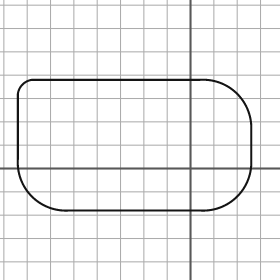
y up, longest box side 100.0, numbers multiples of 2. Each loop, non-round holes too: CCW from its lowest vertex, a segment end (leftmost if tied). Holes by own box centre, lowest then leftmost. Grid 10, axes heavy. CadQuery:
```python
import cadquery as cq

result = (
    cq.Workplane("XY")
    .moveTo(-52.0, -18.0)
    .lineTo(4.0, -18.0)
    .threePointArc((20.0, -12.0), (26.0, 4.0))
    .lineTo(26.0, 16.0)
    .threePointArc((20.0, 32.0), (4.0, 38.0))
    .lineTo(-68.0, 38.0)
    .threePointArc((-72.0, 36.0), (-74.0, 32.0))
    .lineTo(-74.0, 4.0)
    .threePointArc((-68.0, -12.0), (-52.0, -18.0))
    .close()
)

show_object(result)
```